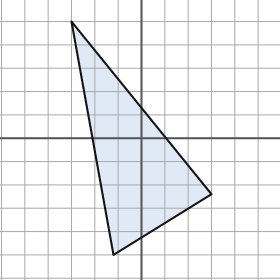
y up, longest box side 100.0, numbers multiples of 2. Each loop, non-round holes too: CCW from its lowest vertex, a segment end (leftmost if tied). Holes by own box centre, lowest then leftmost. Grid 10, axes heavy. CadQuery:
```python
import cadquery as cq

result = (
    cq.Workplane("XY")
    .moveTo(-12.0, -50.0)
    .lineTo(30.0, -24.0)
    .lineTo(-30.0, 50.0)
    .close()
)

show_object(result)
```